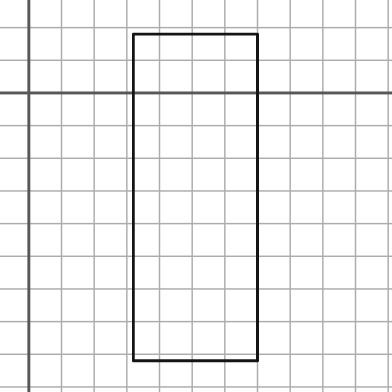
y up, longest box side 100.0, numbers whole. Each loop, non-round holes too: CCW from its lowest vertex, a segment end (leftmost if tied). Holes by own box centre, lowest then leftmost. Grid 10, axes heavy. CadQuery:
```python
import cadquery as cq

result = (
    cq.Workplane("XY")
    .moveTo(32.0, -82.0)
    .lineTo(70.0, -82.0)
    .lineTo(70.0, 18.0)
    .lineTo(32.0, 18.0)
    .close()
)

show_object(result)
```